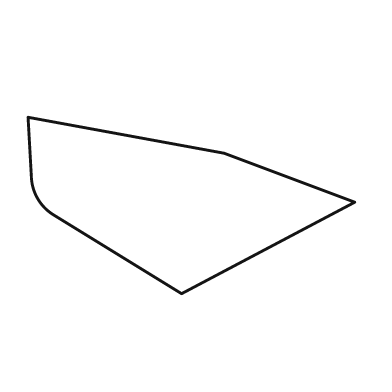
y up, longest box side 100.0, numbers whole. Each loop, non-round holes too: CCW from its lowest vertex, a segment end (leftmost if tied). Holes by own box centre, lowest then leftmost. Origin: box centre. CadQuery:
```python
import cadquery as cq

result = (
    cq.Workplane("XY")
    .moveTo(-3.0, -27.0)
    .lineTo(50.0, 1.0)
    .lineTo(10.0, 16.0)
    .lineTo(-50.0, 27.0)
    .lineTo(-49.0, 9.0)
    .threePointArc((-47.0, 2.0), (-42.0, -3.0))
    .close()
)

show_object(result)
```